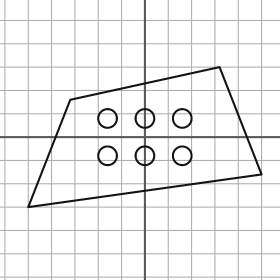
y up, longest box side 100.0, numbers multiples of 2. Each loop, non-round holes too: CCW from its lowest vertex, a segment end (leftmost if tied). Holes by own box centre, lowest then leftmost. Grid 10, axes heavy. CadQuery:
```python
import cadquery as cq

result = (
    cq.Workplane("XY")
    .moveTo(-50.0, -30.0)
    .lineTo(50.0, -16.0)
    .lineTo(32.0, 30.0)
    .lineTo(-32.0, 16.0)
    .close()
    .moveTo(-16.0, -8.0)
    .circle(4.0)
    .moveTo(0.0, -8.0)
    .circle(4.0)
    .moveTo(16.0, -8.0)
    .circle(4.0)
    .moveTo(-16.0, 8.0)
    .circle(4.0)
    .moveTo(0.0, 8.0)
    .circle(4.0)
    .moveTo(16.0, 8.0)
    .circle(4.0)
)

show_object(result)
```